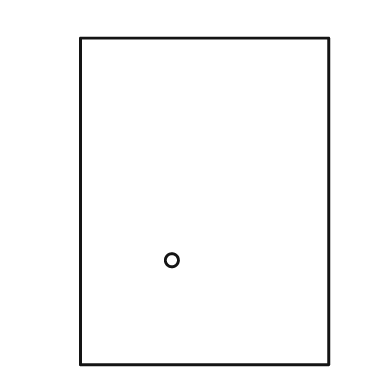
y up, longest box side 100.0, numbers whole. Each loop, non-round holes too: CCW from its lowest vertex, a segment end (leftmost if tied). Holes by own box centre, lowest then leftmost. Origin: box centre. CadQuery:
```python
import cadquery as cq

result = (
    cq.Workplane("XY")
    .moveTo(-38.0, -50.0)
    .lineTo(38.0, -50.0)
    .lineTo(38.0, 50.0)
    .lineTo(-38.0, 50.0)
    .close()
    .moveTo(-10.0, -18.0)
    .circle(2.0)
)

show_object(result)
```